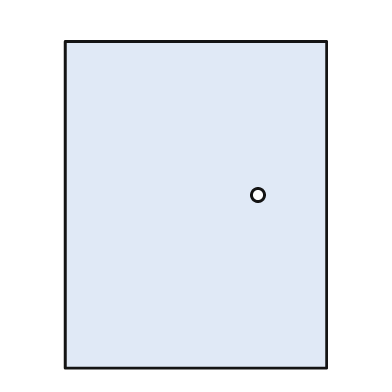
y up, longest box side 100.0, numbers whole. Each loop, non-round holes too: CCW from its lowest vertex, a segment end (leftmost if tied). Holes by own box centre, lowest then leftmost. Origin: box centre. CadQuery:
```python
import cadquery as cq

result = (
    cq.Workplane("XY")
    .moveTo(-40.0, -50.0)
    .lineTo(40.0, -50.0)
    .lineTo(40.0, 50.0)
    .lineTo(-40.0, 50.0)
    .close()
    .moveTo(19.0, 3.0)
    .circle(2.0)
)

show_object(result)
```